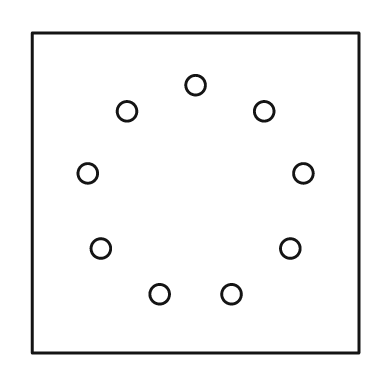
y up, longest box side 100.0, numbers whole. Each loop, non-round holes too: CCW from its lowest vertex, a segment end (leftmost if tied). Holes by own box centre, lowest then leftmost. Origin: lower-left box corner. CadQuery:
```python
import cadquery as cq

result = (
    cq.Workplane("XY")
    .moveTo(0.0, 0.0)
    .lineTo(100.0, 0.0)
    .lineTo(100.0, 98.0)
    .lineTo(0.0, 98.0)
    .close()
    .moveTo(39.0, 18.0)
    .circle(3.0)
    .moveTo(61.0, 18.0)
    .circle(3.0)
    .moveTo(21.0, 32.0)
    .circle(3.0)
    .moveTo(79.0, 32.0)
    .circle(3.0)
    .moveTo(17.0, 55.0)
    .circle(3.0)
    .moveTo(83.0, 55.0)
    .circle(3.0)
    .moveTo(29.0, 74.0)
    .circle(3.0)
    .moveTo(71.0, 74.0)
    .circle(3.0)
    .moveTo(50.0, 82.0)
    .circle(3.0)
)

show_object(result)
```